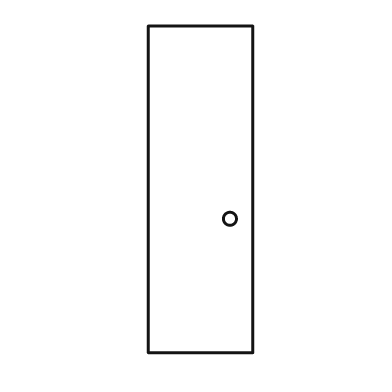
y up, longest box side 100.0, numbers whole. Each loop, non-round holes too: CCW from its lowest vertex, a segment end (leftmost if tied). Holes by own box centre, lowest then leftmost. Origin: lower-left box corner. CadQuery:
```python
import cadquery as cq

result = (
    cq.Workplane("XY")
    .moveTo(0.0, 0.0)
    .lineTo(32.0, 0.0)
    .lineTo(32.0, 100.0)
    .lineTo(0.0, 100.0)
    .close()
    .moveTo(25.0, 41.0)
    .circle(2.0)
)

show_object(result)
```